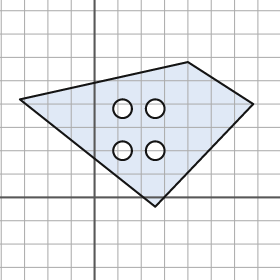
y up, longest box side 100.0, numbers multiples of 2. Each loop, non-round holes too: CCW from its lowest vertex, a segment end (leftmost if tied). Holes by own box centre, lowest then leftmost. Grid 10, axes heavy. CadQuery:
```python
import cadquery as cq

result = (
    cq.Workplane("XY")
    .moveTo(26.0, -4.0)
    .lineTo(68.0, 40.0)
    .lineTo(40.0, 58.0)
    .lineTo(-32.0, 42.0)
    .close()
    .moveTo(12.0, 20.0)
    .circle(4.0)
    .moveTo(26.0, 20.0)
    .circle(4.0)
    .moveTo(12.0, 38.0)
    .circle(4.0)
    .moveTo(26.0, 38.0)
    .circle(4.0)
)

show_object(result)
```